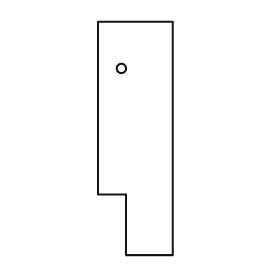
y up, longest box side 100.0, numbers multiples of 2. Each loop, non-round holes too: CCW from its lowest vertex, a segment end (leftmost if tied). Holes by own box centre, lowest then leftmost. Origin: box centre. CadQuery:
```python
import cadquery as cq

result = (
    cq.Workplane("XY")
    .moveTo(-4.0, -50.0)
    .lineTo(16.0, -50.0)
    .lineTo(16.0, 50.0)
    .lineTo(-16.0, 50.0)
    .lineTo(-16.0, -24.0)
    .lineTo(-4.0, -24.0)
    .close()
    .moveTo(-6.0, 30.0)
    .circle(2.0)
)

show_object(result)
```